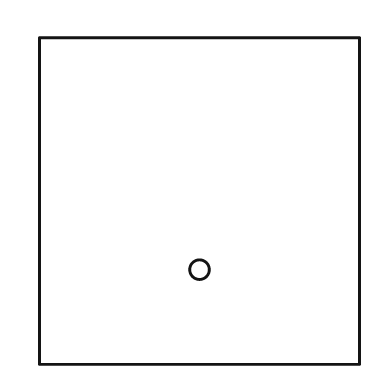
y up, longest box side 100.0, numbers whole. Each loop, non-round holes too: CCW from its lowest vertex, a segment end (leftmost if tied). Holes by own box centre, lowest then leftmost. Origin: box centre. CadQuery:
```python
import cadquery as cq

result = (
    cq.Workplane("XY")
    .moveTo(-49.0, -50.0)
    .lineTo(49.0, -50.0)
    .lineTo(49.0, 50.0)
    .lineTo(-49.0, 50.0)
    .close()
    .moveTo(0.0, -21.0)
    .circle(3.0)
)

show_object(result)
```